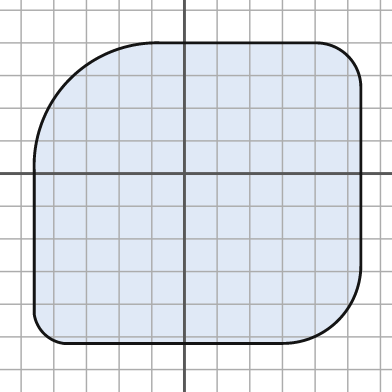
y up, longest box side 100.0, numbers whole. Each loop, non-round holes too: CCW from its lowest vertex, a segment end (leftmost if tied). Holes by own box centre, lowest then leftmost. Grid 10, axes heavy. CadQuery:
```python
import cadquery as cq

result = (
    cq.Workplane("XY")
    .moveTo(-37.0, -52.0)
    .lineTo(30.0, -52.0)
    .threePointArc((47.0, -45.0), (54.0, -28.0))
    .lineTo(54.0, 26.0)
    .threePointArc((50.0, 36.0), (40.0, 40.0))
    .lineTo(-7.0, 40.0)
    .threePointArc((-35.0, 29.0), (-46.0, 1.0))
    .lineTo(-46.0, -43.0)
    .threePointArc((-43.0, -49.0), (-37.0, -52.0))
    .close()
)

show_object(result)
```